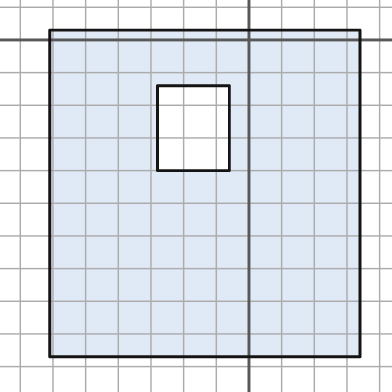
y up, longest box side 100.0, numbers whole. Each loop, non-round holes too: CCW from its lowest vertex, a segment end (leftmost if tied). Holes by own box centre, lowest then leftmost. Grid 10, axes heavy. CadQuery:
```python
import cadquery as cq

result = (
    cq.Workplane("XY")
    .moveTo(-61.0, -97.0)
    .lineTo(34.0, -97.0)
    .lineTo(34.0, 3.0)
    .lineTo(-61.0, 3.0)
    .close()
    .moveTo(-28.0, -40.0)
    .lineTo(-6.0, -40.0)
    .lineTo(-6.0, -14.0)
    .lineTo(-28.0, -14.0)
    .close()
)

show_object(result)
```